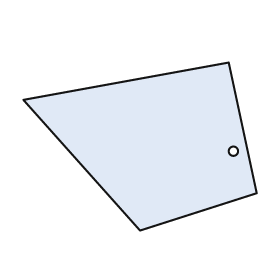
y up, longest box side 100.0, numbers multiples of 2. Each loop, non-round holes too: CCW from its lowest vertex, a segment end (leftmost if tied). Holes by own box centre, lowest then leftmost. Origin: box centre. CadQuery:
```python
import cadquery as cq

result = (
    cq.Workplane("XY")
    .moveTo(0.0, -36.0)
    .lineTo(50.0, -20.0)
    .lineTo(38.0, 36.0)
    .lineTo(-50.0, 20.0)
    .close()
    .moveTo(40.0, -2.0)
    .circle(2.0)
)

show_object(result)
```